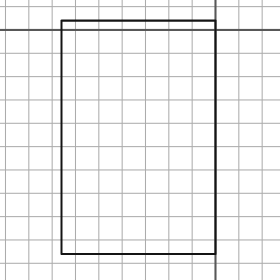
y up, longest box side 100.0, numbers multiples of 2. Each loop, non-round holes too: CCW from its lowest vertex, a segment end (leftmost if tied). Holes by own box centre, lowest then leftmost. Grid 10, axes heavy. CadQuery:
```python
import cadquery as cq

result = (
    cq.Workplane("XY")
    .moveTo(-66.0, -96.0)
    .lineTo(0.0, -96.0)
    .lineTo(0.0, 4.0)
    .lineTo(-66.0, 4.0)
    .close()
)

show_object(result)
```